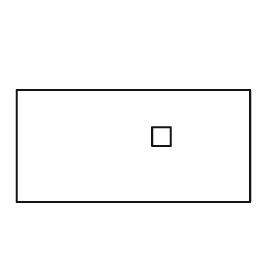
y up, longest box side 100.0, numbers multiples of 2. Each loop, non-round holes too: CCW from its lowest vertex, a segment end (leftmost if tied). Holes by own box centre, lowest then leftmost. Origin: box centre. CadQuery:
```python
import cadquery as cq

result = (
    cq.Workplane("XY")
    .moveTo(-50.0, -24.0)
    .lineTo(50.0, -24.0)
    .lineTo(50.0, 24.0)
    .lineTo(-50.0, 24.0)
    .close()
    .moveTo(8.0, 0.0)
    .lineTo(16.0, 0.0)
    .lineTo(16.0, 8.0)
    .lineTo(8.0, 8.0)
    .close()
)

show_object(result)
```